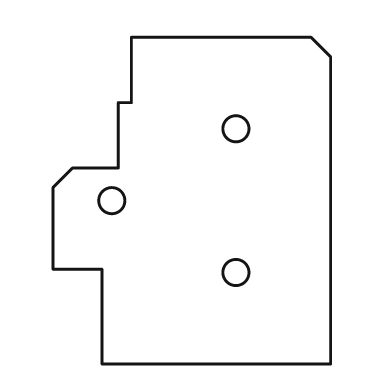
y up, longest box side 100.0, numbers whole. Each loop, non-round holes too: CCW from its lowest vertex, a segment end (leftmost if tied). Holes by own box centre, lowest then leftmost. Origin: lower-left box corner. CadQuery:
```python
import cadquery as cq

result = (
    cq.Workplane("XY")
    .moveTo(15.0, 0.0)
    .lineTo(85.0, 0.0)
    .lineTo(85.0, 94.0)
    .lineTo(79.0, 100.0)
    .lineTo(24.0, 100.0)
    .lineTo(24.0, 80.0)
    .lineTo(20.0, 80.0)
    .lineTo(20.0, 60.0)
    .lineTo(6.0, 60.0)
    .lineTo(0.0, 54.0)
    .lineTo(0.0, 29.0)
    .lineTo(15.0, 29.0)
    .close()
    .moveTo(56.0, 28.0)
    .circle(4.0)
    .moveTo(18.0, 50.0)
    .circle(4.0)
    .moveTo(56.0, 72.0)
    .circle(4.0)
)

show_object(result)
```